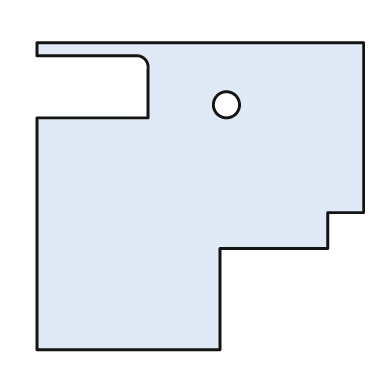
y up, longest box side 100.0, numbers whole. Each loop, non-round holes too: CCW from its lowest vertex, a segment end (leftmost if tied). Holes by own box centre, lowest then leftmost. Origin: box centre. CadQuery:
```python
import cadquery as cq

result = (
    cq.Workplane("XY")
    .moveTo(-50.0, -47.0)
    .lineTo(6.0, -47.0)
    .lineTo(6.0, -16.0)
    .lineTo(39.0, -16.0)
    .lineTo(39.0, -5.0)
    .lineTo(50.0, -5.0)
    .lineTo(50.0, 47.0)
    .lineTo(-50.0, 47.0)
    .lineTo(-50.0, 43.0)
    .lineTo(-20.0, 43.0)
    .threePointArc((-17.0, 42.0), (-16.0, 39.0))
    .lineTo(-16.0, 24.0)
    .lineTo(-50.0, 24.0)
    .close()
    .moveTo(8.0, 28.0)
    .circle(4.0)
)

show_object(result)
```